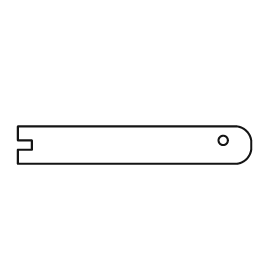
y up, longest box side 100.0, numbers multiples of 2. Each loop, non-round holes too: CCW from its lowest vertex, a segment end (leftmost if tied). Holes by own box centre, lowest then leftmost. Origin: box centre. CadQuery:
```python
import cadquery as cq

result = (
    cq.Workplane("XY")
    .moveTo(-50.0, -8.0)
    .lineTo(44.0, -8.0)
    .threePointArc((48.0, -6.0), (50.0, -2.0))
    .lineTo(50.0, 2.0)
    .threePointArc((48.0, 6.0), (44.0, 8.0))
    .lineTo(-50.0, 8.0)
    .lineTo(-50.0, 2.0)
    .lineTo(-44.0, 2.0)
    .lineTo(-44.0, -2.0)
    .lineTo(-50.0, -2.0)
    .close()
    .moveTo(38.0, 2.0)
    .circle(2.0)
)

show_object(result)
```